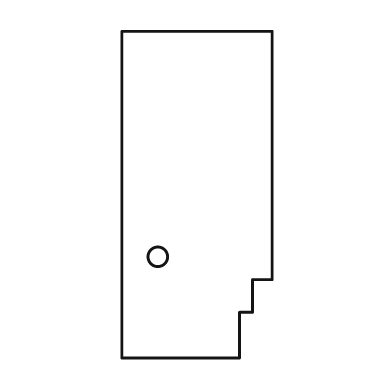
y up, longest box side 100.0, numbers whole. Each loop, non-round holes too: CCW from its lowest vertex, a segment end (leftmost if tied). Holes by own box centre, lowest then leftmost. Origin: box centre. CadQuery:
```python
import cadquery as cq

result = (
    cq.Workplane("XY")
    .moveTo(-23.0, -50.0)
    .lineTo(13.0, -50.0)
    .lineTo(13.0, -36.0)
    .lineTo(17.0, -36.0)
    .lineTo(17.0, -26.0)
    .lineTo(23.0, -26.0)
    .lineTo(23.0, 50.0)
    .lineTo(-23.0, 50.0)
    .close()
    .moveTo(-12.0, -19.0)
    .circle(3.0)
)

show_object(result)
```